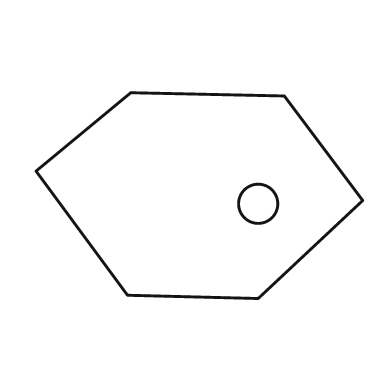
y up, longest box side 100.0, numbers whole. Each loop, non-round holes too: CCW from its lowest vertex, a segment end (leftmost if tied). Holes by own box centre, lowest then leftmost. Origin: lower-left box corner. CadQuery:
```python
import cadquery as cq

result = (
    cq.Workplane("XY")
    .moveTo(68.0, 0.0)
    .lineTo(100.0, 30.0)
    .lineTo(76.0, 62.0)
    .lineTo(29.0, 63.0)
    .lineTo(0.0, 39.0)
    .lineTo(28.0, 1.0)
    .close()
    .moveTo(68.0, 29.0)
    .circle(6.0)
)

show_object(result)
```